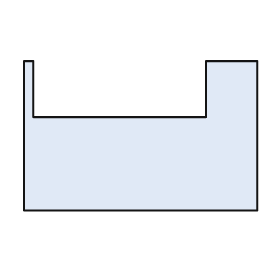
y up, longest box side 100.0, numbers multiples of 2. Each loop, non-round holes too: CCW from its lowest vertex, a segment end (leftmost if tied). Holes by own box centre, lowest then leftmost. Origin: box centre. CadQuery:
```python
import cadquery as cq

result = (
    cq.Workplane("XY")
    .moveTo(-50.0, -32.0)
    .lineTo(50.0, -32.0)
    .lineTo(50.0, 32.0)
    .lineTo(28.0, 32.0)
    .lineTo(28.0, 8.0)
    .lineTo(-46.0, 8.0)
    .lineTo(-46.0, 32.0)
    .lineTo(-50.0, 32.0)
    .close()
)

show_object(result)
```